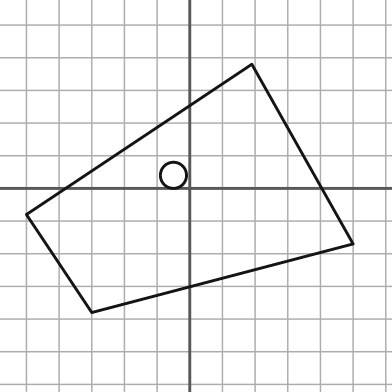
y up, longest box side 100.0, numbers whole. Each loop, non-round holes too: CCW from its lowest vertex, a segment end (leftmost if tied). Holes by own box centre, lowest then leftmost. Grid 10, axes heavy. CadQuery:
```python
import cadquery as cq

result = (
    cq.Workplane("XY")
    .moveTo(-30.0, -38.0)
    .lineTo(50.0, -17.0)
    .lineTo(19.0, 38.0)
    .lineTo(-50.0, -8.0)
    .close()
    .moveTo(-5.0, 4.0)
    .circle(4.0)
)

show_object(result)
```